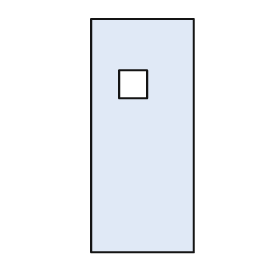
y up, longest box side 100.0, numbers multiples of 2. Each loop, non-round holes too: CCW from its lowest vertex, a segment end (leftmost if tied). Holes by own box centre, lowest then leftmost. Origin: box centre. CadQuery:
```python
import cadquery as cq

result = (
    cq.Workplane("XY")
    .moveTo(-22.0, -50.0)
    .lineTo(22.0, -50.0)
    .lineTo(22.0, 50.0)
    .lineTo(-22.0, 50.0)
    .close()
    .moveTo(-10.0, 16.0)
    .lineTo(2.0, 16.0)
    .lineTo(2.0, 28.0)
    .lineTo(-10.0, 28.0)
    .close()
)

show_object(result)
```